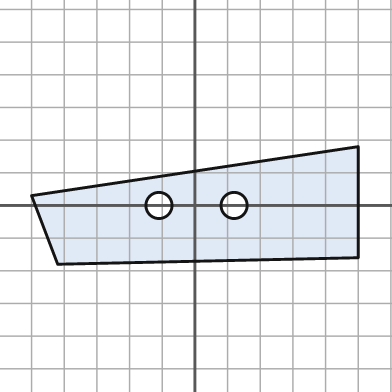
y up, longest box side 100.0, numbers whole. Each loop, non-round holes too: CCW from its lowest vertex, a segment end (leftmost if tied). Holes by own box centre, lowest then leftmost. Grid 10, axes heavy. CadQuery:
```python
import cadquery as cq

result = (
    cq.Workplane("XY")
    .moveTo(-42.0, -18.0)
    .lineTo(50.0, -16.0)
    .lineTo(50.0, 18.0)
    .lineTo(-50.0, 3.0)
    .close()
    .moveTo(-11.0, 0.0)
    .circle(4.0)
    .moveTo(12.0, 0.0)
    .circle(4.0)
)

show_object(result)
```